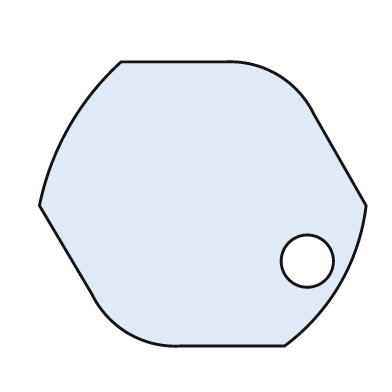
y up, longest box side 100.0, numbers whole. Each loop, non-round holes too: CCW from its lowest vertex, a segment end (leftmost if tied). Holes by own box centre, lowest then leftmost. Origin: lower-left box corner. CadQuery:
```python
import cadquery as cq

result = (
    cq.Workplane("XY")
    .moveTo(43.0, 0.0)
    .lineTo(75.0, 0.0)
    .threePointArc((92.0, 19.0), (100.0, 43.0))
    .lineTo(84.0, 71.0)
    .threePointArc((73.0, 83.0), (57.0, 87.0))
    .lineTo(25.0, 87.0)
    .threePointArc((9.0, 67.0), (0.0, 43.0))
    .lineTo(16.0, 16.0)
    .threePointArc((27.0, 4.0), (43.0, 0.0))
    .close()
    .moveTo(82.0, 26.0)
    .circle(8.0)
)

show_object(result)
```